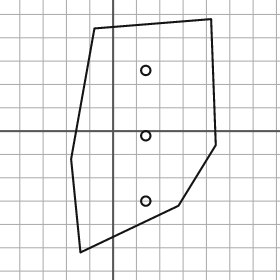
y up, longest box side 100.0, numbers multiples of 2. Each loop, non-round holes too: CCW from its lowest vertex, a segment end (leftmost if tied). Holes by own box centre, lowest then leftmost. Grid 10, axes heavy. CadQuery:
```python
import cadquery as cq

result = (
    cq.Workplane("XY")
    .moveTo(-14.0, -52.0)
    .lineTo(28.0, -32.0)
    .lineTo(44.0, -6.0)
    .lineTo(42.0, 48.0)
    .lineTo(-8.0, 44.0)
    .lineTo(-18.0, -12.0)
    .close()
    .moveTo(14.0, -30.0)
    .circle(2.0)
    .moveTo(14.0, -2.0)
    .circle(2.0)
    .moveTo(14.0, 26.0)
    .circle(2.0)
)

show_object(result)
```